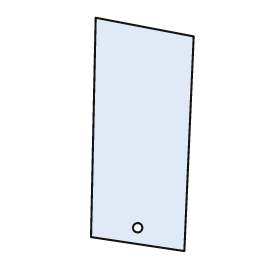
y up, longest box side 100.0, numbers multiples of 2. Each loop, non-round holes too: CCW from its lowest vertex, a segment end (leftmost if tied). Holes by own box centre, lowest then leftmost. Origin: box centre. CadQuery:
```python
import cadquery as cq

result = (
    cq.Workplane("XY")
    .moveTo(18.0, -50.0)
    .lineTo(22.0, 42.0)
    .lineTo(-20.0, 50.0)
    .lineTo(-22.0, -44.0)
    .close()
    .moveTo(-2.0, -40.0)
    .circle(2.0)
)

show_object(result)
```